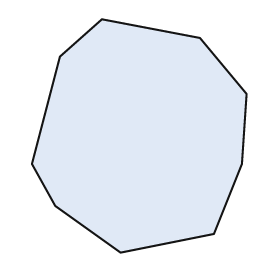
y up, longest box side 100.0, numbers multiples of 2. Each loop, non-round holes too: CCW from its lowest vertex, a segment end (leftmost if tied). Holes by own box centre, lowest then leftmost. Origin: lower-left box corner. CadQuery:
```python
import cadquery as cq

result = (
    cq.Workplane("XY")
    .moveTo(38.0, 0.0)
    .lineTo(78.0, 8.0)
    .lineTo(90.0, 38.0)
    .lineTo(92.0, 68.0)
    .lineTo(72.0, 92.0)
    .lineTo(30.0, 100.0)
    .lineTo(12.0, 84.0)
    .lineTo(0.0, 38.0)
    .lineTo(10.0, 20.0)
    .close()
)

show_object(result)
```